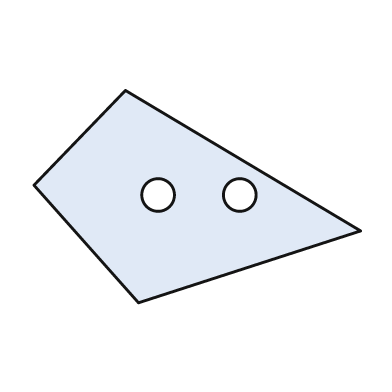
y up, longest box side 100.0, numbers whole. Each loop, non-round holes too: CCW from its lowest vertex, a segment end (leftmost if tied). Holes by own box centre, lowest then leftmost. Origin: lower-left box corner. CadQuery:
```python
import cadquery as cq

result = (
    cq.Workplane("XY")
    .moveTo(32.0, 0.0)
    .lineTo(100.0, 22.0)
    .lineTo(28.0, 65.0)
    .lineTo(0.0, 36.0)
    .close()
    .moveTo(38.0, 33.0)
    .circle(5.0)
    .moveTo(63.0, 33.0)
    .circle(5.0)
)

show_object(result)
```